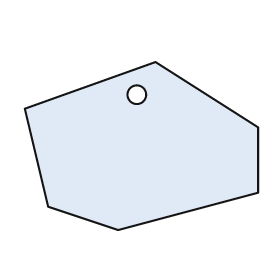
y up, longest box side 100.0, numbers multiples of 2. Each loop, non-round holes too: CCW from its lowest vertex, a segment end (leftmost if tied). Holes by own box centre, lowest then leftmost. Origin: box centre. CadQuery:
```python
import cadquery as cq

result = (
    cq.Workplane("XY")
    .moveTo(-10.0, -36.0)
    .lineTo(50.0, -20.0)
    .lineTo(50.0, 8.0)
    .lineTo(6.0, 36.0)
    .lineTo(-50.0, 16.0)
    .lineTo(-40.0, -26.0)
    .close()
    .moveTo(-2.0, 22.0)
    .circle(4.0)
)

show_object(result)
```